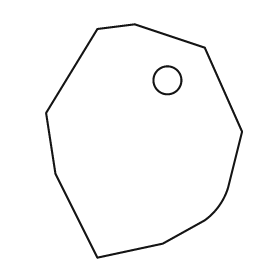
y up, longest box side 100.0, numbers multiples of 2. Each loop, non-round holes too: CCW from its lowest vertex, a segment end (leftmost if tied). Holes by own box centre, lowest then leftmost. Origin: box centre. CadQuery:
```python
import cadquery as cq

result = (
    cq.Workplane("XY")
    .moveTo(-20.0, -50.0)
    .lineTo(8.0, -44.0)
    .lineTo(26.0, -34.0)
    .threePointArc((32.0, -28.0), (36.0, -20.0))
    .lineTo(42.0, 4.0)
    .lineTo(26.0, 40.0)
    .lineTo(-4.0, 50.0)
    .lineTo(-20.0, 48.0)
    .lineTo(-42.0, 12.0)
    .lineTo(-38.0, -14.0)
    .close()
    .moveTo(10.0, 26.0)
    .circle(6.0)
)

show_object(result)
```